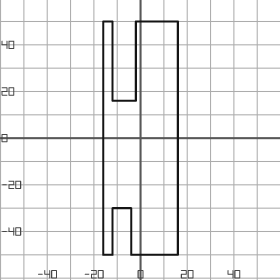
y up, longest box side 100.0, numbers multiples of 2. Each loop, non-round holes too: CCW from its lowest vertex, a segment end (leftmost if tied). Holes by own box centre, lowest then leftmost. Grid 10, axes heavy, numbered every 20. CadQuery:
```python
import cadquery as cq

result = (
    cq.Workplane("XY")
    .moveTo(-16.0, -50.0)
    .lineTo(-12.0, -50.0)
    .lineTo(-12.0, -30.0)
    .lineTo(-4.0, -30.0)
    .lineTo(-4.0, -50.0)
    .lineTo(16.0, -50.0)
    .lineTo(16.0, 50.0)
    .lineTo(-2.0, 50.0)
    .lineTo(-2.0, 16.0)
    .lineTo(-12.0, 16.0)
    .lineTo(-12.0, 50.0)
    .lineTo(-16.0, 50.0)
    .close()
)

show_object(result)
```